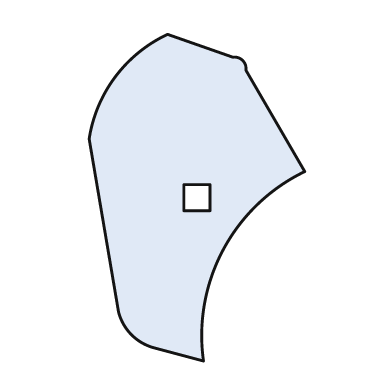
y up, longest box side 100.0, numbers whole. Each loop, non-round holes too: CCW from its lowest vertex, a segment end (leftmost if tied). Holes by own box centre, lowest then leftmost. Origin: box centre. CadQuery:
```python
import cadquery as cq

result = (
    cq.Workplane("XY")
    .moveTo(2.0, -50.0)
    .threePointArc((8.0, -16.0), (33.0, 8.0))
    .lineTo(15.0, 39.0)
    .threePointArc((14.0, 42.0), (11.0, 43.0))
    .lineTo(-9.0, 50.0)
    .threePointArc((-25.0, 37.0), (-33.0, 18.0))
    .lineTo(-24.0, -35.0)
    .threePointArc((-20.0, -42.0), (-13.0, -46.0))
    .close()
    .moveTo(-4.0, -4.0)
    .lineTo(4.0, -4.0)
    .lineTo(4.0, 4.0)
    .lineTo(-4.0, 4.0)
    .close()
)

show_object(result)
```